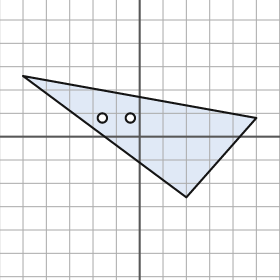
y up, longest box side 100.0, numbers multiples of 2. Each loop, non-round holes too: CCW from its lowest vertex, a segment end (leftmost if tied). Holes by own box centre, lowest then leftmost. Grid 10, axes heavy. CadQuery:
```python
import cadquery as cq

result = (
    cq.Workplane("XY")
    .moveTo(20.0, -26.0)
    .lineTo(50.0, 8.0)
    .lineTo(-50.0, 26.0)
    .close()
    .moveTo(-16.0, 8.0)
    .circle(2.0)
    .moveTo(-4.0, 8.0)
    .circle(2.0)
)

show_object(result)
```